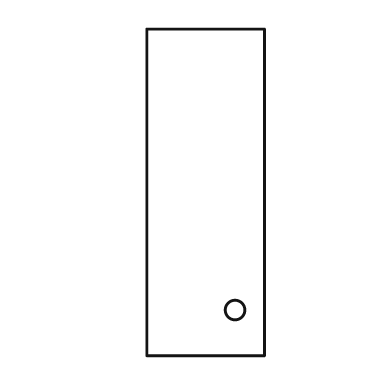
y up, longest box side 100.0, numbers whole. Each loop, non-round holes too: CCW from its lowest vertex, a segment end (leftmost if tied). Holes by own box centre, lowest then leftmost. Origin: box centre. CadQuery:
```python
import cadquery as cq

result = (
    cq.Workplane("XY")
    .moveTo(-18.0, -50.0)
    .lineTo(18.0, -50.0)
    .lineTo(18.0, 50.0)
    .lineTo(-18.0, 50.0)
    .close()
    .moveTo(9.0, -36.0)
    .circle(3.0)
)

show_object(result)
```